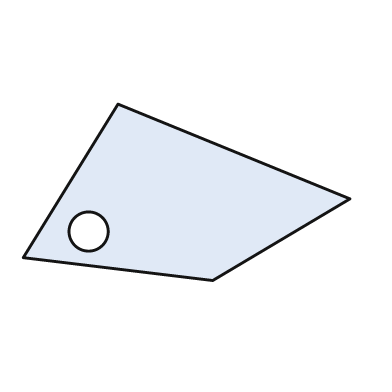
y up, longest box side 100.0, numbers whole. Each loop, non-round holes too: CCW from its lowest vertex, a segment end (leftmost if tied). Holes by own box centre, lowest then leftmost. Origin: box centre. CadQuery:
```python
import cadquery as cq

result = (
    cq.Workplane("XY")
    .moveTo(8.0, -27.0)
    .lineTo(50.0, -2.0)
    .lineTo(-21.0, 27.0)
    .lineTo(-50.0, -20.0)
    .close()
    .moveTo(-30.0, -12.0)
    .circle(6.0)
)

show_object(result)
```